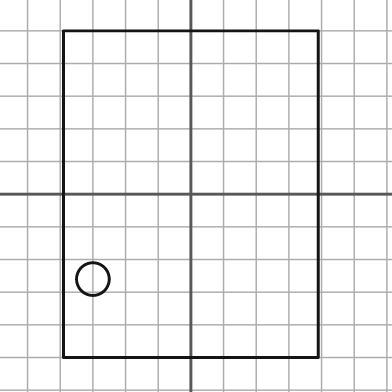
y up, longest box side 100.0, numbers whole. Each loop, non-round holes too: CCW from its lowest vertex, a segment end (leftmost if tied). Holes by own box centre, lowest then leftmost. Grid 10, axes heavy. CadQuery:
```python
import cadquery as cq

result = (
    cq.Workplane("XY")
    .moveTo(-39.0, -50.0)
    .lineTo(39.0, -50.0)
    .lineTo(39.0, 50.0)
    .lineTo(-39.0, 50.0)
    .close()
    .moveTo(-30.0, -26.0)
    .circle(5.0)
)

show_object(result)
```